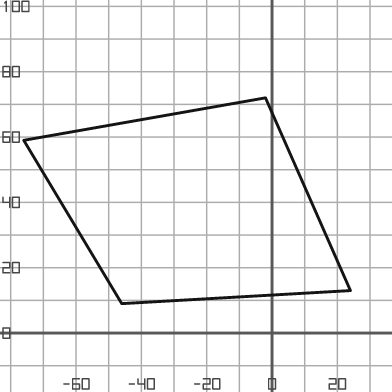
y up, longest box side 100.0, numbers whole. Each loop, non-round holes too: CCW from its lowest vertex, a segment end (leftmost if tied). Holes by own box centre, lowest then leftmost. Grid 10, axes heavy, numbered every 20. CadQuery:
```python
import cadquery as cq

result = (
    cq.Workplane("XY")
    .moveTo(-46.0, 9.0)
    .lineTo(24.0, 13.0)
    .lineTo(-2.0, 72.0)
    .lineTo(-76.0, 59.0)
    .close()
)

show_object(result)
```